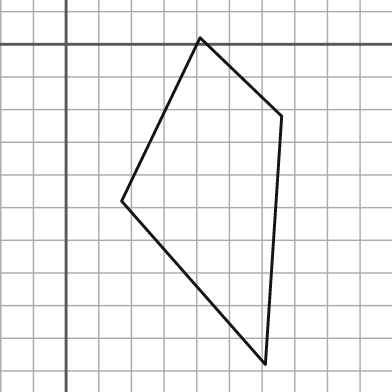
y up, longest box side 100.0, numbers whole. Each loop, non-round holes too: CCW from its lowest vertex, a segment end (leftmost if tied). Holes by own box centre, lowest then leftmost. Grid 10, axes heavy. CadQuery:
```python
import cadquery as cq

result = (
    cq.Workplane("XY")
    .moveTo(61.0, -98.0)
    .lineTo(66.0, -22.0)
    .lineTo(41.0, 2.0)
    .lineTo(17.0, -48.0)
    .close()
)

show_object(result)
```